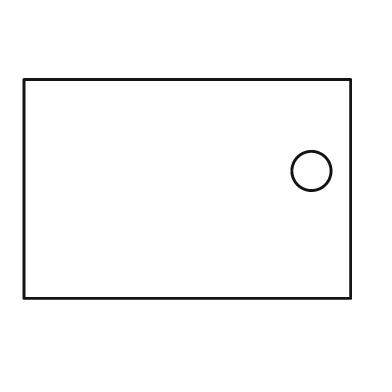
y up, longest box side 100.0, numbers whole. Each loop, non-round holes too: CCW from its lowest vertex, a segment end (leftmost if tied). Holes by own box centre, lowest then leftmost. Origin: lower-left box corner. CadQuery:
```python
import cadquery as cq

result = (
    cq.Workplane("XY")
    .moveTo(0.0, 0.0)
    .lineTo(100.0, 0.0)
    .lineTo(100.0, 67.0)
    .lineTo(0.0, 67.0)
    .close()
    .moveTo(88.0, 39.0)
    .circle(6.0)
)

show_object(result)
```